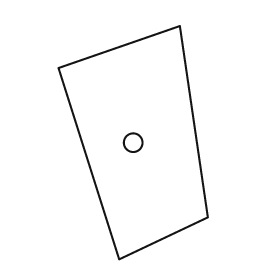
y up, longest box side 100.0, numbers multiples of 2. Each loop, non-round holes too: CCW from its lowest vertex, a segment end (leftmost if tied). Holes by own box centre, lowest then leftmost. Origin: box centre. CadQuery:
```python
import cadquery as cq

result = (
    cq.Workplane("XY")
    .moveTo(-6.0, -50.0)
    .lineTo(32.0, -32.0)
    .lineTo(20.0, 50.0)
    .lineTo(-32.0, 32.0)
    .close()
    .moveTo(0.0, 0.0)
    .circle(4.0)
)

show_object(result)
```